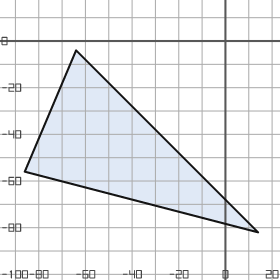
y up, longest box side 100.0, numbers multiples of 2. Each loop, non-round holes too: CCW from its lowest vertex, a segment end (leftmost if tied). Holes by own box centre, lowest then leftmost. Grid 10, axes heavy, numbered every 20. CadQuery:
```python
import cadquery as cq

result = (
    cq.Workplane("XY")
    .moveTo(14.0, -82.0)
    .lineTo(-64.0, -4.0)
    .lineTo(-86.0, -56.0)
    .close()
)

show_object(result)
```